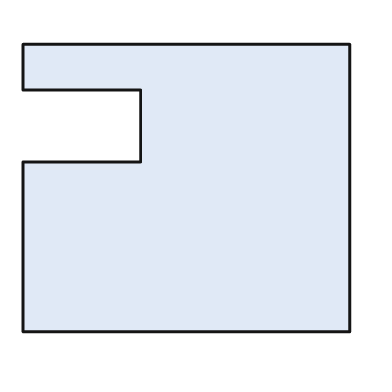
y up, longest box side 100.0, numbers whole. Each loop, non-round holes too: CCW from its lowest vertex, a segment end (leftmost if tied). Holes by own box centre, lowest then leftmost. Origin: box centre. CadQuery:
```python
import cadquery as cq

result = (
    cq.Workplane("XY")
    .moveTo(-50.0, -44.0)
    .lineTo(50.0, -44.0)
    .lineTo(50.0, 44.0)
    .lineTo(-50.0, 44.0)
    .lineTo(-50.0, 30.0)
    .lineTo(-14.0, 30.0)
    .lineTo(-14.0, 8.0)
    .lineTo(-50.0, 8.0)
    .close()
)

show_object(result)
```